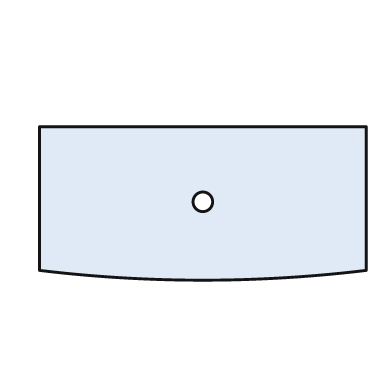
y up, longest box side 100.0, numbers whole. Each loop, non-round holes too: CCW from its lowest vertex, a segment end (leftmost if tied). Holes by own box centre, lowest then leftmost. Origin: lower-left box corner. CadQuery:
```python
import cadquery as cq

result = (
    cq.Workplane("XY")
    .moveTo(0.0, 3.0)
    .threePointArc((50.0, 0.0), (100.0, 3.0))
    .lineTo(100.0, 47.0)
    .lineTo(0.0, 47.0)
    .close()
    .moveTo(50.0, 24.0)
    .circle(3.0)
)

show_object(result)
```